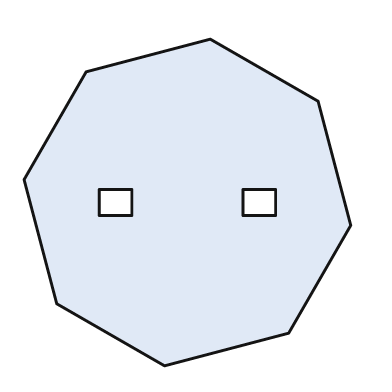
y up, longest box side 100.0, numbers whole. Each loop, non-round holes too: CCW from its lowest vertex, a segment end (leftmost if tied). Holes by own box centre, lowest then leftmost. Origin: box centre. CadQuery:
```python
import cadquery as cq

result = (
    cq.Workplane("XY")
    .moveTo(-7.0, -50.0)
    .lineTo(31.0, -40.0)
    .lineTo(50.0, -7.0)
    .lineTo(40.0, 31.0)
    .lineTo(7.0, 50.0)
    .lineTo(-31.0, 40.0)
    .lineTo(-50.0, 7.0)
    .lineTo(-40.0, -31.0)
    .close()
    .moveTo(-27.0, -4.0)
    .lineTo(-17.0, -4.0)
    .lineTo(-17.0, 4.0)
    .lineTo(-27.0, 4.0)
    .close()
    .moveTo(17.0, -4.0)
    .lineTo(27.0, -4.0)
    .lineTo(27.0, 4.0)
    .lineTo(17.0, 4.0)
    .close()
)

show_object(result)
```